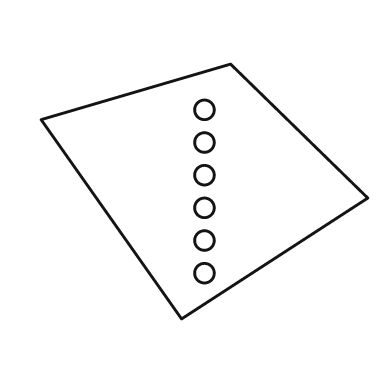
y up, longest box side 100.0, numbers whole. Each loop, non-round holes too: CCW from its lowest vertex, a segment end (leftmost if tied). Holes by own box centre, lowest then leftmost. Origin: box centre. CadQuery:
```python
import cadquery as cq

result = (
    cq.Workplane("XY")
    .moveTo(-7.0, -39.0)
    .lineTo(50.0, -2.0)
    .lineTo(8.0, 39.0)
    .lineTo(-50.0, 22.0)
    .close()
    .moveTo(0.0, -25.0)
    .circle(3.0)
    .moveTo(0.0, -15.0)
    .circle(3.0)
    .moveTo(0.0, -5.0)
    .circle(3.0)
    .moveTo(0.0, 5.0)
    .circle(3.0)
    .moveTo(0.0, 15.0)
    .circle(3.0)
    .moveTo(0.0, 25.0)
    .circle(3.0)
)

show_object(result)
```